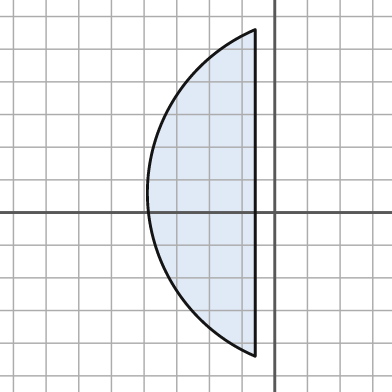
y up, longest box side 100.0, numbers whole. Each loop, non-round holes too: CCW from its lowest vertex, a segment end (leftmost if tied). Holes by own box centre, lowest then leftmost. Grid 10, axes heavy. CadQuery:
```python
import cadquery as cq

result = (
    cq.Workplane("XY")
    .moveTo(-6.0, -44.0)
    .lineTo(-6.0, 56.0)
    .threePointArc((-39.0, 6.0), (-6.0, -44.0))
    .close()
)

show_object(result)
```